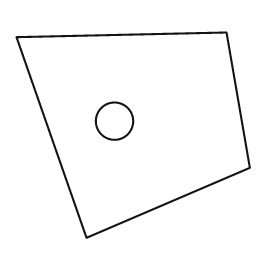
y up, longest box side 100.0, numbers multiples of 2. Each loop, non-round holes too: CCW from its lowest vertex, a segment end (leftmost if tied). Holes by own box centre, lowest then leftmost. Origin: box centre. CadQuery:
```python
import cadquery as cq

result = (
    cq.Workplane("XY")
    .moveTo(-20.0, -44.0)
    .lineTo(50.0, -14.0)
    .lineTo(40.0, 44.0)
    .lineTo(-50.0, 42.0)
    .close()
    .moveTo(-8.0, 6.0)
    .circle(8.0)
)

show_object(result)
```